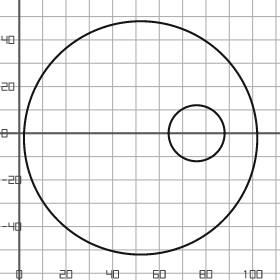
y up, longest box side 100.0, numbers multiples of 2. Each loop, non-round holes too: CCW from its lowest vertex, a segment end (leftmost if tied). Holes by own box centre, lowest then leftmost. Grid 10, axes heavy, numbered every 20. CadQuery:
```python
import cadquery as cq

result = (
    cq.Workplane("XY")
    .moveTo(52.0, -2.0)
    .circle(50.0)
    .moveTo(76.0, 0.0)
    .circle(12.0)
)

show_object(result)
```